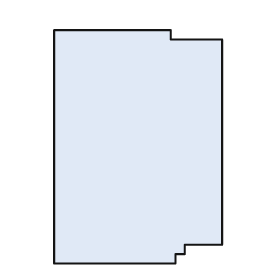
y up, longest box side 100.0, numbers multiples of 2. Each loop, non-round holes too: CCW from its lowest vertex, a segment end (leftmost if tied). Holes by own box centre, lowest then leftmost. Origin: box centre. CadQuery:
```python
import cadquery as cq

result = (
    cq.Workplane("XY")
    .moveTo(-36.0, -50.0)
    .lineTo(16.0, -50.0)
    .lineTo(16.0, -46.0)
    .lineTo(20.0, -46.0)
    .lineTo(20.0, -42.0)
    .lineTo(36.0, -42.0)
    .lineTo(36.0, 46.0)
    .lineTo(14.0, 46.0)
    .lineTo(14.0, 50.0)
    .lineTo(-36.0, 50.0)
    .close()
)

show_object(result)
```